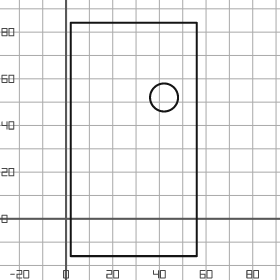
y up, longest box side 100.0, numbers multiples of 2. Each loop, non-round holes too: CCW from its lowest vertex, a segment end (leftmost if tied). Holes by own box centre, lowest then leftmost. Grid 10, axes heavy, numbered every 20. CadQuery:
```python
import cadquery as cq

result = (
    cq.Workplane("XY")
    .moveTo(2.0, -16.0)
    .lineTo(56.0, -16.0)
    .lineTo(56.0, 84.0)
    .lineTo(2.0, 84.0)
    .close()
    .moveTo(42.0, 52.0)
    .circle(6.0)
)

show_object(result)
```